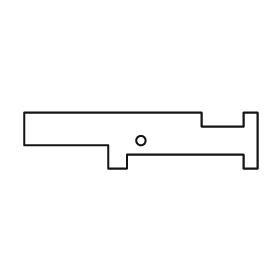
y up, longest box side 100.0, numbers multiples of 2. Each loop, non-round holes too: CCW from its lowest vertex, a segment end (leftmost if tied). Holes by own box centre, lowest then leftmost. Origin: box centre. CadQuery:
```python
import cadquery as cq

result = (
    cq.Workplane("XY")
    .moveTo(-14.0, -12.0)
    .lineTo(-6.0, -12.0)
    .lineTo(-6.0, -6.0)
    .lineTo(44.0, -6.0)
    .lineTo(44.0, -12.0)
    .lineTo(50.0, -12.0)
    .lineTo(50.0, 12.0)
    .lineTo(44.0, 12.0)
    .lineTo(44.0, 6.0)
    .lineTo(26.0, 6.0)
    .lineTo(26.0, 12.0)
    .lineTo(-50.0, 12.0)
    .lineTo(-50.0, -2.0)
    .lineTo(-14.0, -2.0)
    .close()
    .moveTo(0.0, 0.0)
    .circle(2.0)
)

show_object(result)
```